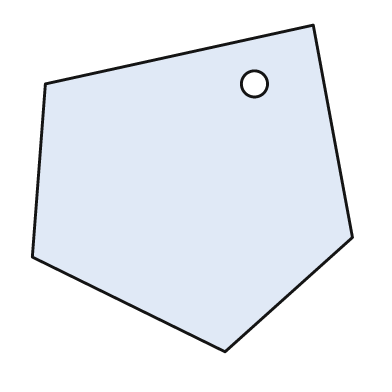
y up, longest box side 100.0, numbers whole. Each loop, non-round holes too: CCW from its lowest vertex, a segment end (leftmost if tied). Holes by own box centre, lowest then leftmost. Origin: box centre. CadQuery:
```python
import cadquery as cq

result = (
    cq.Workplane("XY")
    .moveTo(10.0, -50.0)
    .lineTo(49.0, -15.0)
    .lineTo(37.0, 50.0)
    .lineTo(-45.0, 32.0)
    .lineTo(-49.0, -21.0)
    .close()
    .moveTo(19.0, 32.0)
    .circle(4.0)
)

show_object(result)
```